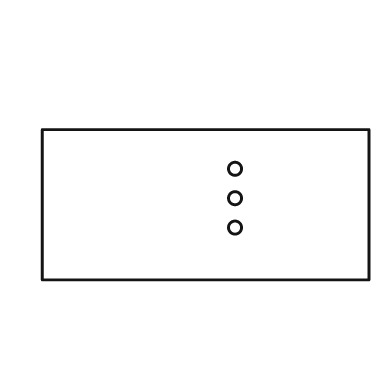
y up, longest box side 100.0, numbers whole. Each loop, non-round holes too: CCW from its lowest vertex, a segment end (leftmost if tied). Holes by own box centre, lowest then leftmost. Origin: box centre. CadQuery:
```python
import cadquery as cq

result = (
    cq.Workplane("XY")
    .moveTo(-50.0, -23.0)
    .lineTo(50.0, -23.0)
    .lineTo(50.0, 23.0)
    .lineTo(-50.0, 23.0)
    .close()
    .moveTo(9.0, -7.0)
    .circle(2.0)
    .moveTo(9.0, 2.0)
    .circle(2.0)
    .moveTo(9.0, 11.0)
    .circle(2.0)
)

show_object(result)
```